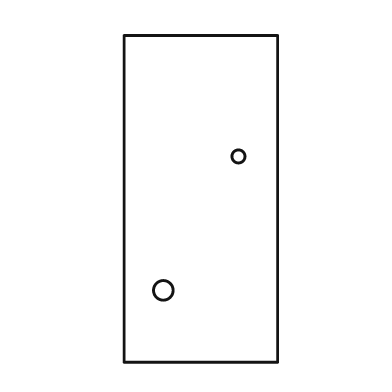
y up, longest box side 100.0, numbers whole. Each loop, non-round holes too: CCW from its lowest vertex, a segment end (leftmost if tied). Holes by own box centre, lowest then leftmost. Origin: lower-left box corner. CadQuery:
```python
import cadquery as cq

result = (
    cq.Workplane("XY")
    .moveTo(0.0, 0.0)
    .lineTo(47.0, 0.0)
    .lineTo(47.0, 100.0)
    .lineTo(0.0, 100.0)
    .close()
    .moveTo(12.0, 22.0)
    .circle(3.0)
    .moveTo(35.0, 63.0)
    .circle(2.0)
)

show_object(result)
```